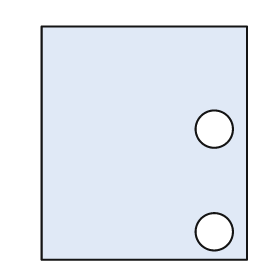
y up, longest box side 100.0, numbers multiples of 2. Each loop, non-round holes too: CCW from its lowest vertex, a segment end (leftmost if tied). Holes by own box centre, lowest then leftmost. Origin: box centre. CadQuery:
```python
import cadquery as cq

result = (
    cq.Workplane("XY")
    .moveTo(-44.0, -50.0)
    .lineTo(44.0, -50.0)
    .lineTo(44.0, 50.0)
    .lineTo(-44.0, 50.0)
    .close()
    .moveTo(30.0, -38.0)
    .circle(8.0)
    .moveTo(30.0, 6.0)
    .circle(8.0)
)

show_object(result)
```